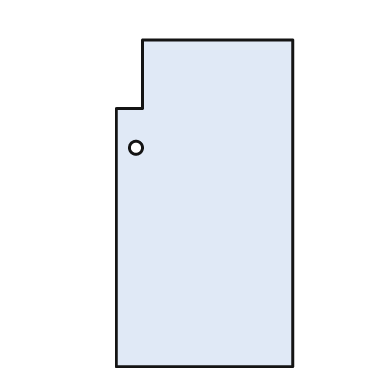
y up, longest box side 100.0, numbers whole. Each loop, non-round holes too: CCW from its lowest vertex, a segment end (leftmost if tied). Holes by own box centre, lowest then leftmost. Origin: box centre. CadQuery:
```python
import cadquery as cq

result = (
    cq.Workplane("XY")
    .moveTo(-27.0, -50.0)
    .lineTo(27.0, -50.0)
    .lineTo(27.0, 50.0)
    .lineTo(-19.0, 50.0)
    .lineTo(-19.0, 29.0)
    .lineTo(-27.0, 29.0)
    .close()
    .moveTo(-21.0, 17.0)
    .circle(2.0)
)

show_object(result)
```